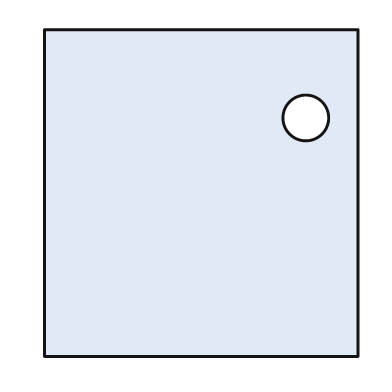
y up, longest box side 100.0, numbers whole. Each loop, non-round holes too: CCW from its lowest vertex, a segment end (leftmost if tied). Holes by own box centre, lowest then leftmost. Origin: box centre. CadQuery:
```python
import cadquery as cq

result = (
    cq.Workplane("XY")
    .moveTo(-48.0, -50.0)
    .lineTo(48.0, -50.0)
    .lineTo(48.0, 50.0)
    .lineTo(-48.0, 50.0)
    .close()
    .moveTo(32.0, 23.0)
    .circle(7.0)
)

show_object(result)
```